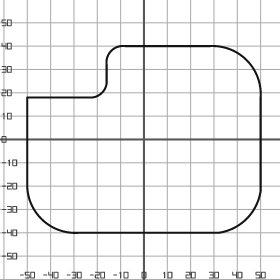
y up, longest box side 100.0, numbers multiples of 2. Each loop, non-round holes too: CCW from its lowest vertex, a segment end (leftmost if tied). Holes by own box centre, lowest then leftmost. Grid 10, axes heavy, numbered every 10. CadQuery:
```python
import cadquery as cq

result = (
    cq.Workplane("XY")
    .moveTo(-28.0, -40.0)
    .lineTo(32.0, -40.0)
    .threePointArc((44.0, -34.0), (50.0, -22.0))
    .lineTo(50.0, 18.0)
    .threePointArc((44.0, 34.0), (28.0, 40.0))
    .lineTo(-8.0, 40.0)
    .threePointArc((-14.0, 38.0), (-16.0, 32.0))
    .lineTo(-16.0, 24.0)
    .threePointArc((-18.0, 20.0), (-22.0, 18.0))
    .lineTo(-50.0, 18.0)
    .lineTo(-50.0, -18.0)
    .threePointArc((-44.0, -34.0), (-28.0, -40.0))
    .close()
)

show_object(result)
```